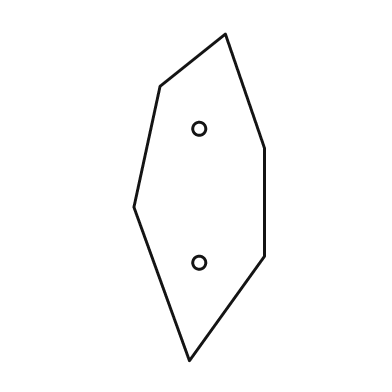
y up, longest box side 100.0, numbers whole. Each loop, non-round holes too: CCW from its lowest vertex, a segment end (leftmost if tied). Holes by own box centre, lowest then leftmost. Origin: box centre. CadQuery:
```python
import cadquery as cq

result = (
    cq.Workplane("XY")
    .moveTo(-3.0, -50.0)
    .lineTo(20.0, -18.0)
    .lineTo(20.0, 15.0)
    .lineTo(8.0, 50.0)
    .lineTo(-12.0, 34.0)
    .lineTo(-20.0, -3.0)
    .close()
    .moveTo(0.0, -20.0)
    .circle(2.0)
    .moveTo(0.0, 21.0)
    .circle(2.0)
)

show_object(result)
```